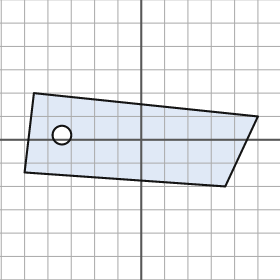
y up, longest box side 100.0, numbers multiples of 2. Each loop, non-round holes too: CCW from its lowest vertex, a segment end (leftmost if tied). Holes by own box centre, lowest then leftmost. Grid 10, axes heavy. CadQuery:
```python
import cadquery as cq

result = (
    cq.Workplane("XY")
    .moveTo(36.0, -20.0)
    .lineTo(50.0, 10.0)
    .lineTo(-46.0, 20.0)
    .lineTo(-50.0, -14.0)
    .close()
    .moveTo(-34.0, 2.0)
    .circle(4.0)
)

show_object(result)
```